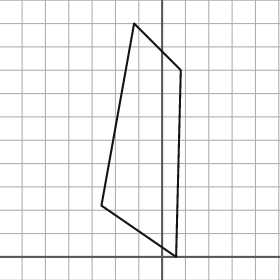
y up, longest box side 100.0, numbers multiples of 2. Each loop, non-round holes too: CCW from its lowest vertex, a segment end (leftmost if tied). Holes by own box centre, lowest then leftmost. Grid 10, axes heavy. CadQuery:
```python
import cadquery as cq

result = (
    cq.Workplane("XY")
    .moveTo(6.0, 0.0)
    .lineTo(8.0, 80.0)
    .lineTo(-12.0, 100.0)
    .lineTo(-26.0, 22.0)
    .close()
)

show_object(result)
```